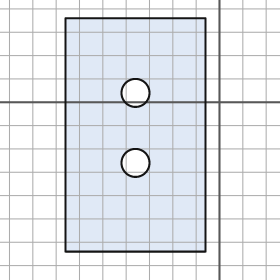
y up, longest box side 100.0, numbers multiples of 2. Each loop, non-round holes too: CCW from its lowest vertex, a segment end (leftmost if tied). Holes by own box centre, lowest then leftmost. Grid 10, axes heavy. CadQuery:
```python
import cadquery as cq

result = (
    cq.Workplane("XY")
    .moveTo(-66.0, -64.0)
    .lineTo(-6.0, -64.0)
    .lineTo(-6.0, 36.0)
    .lineTo(-66.0, 36.0)
    .close()
    .moveTo(-36.0, -26.0)
    .circle(6.0)
    .moveTo(-36.0, 4.0)
    .circle(6.0)
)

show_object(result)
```